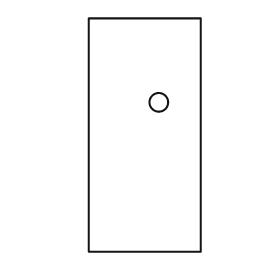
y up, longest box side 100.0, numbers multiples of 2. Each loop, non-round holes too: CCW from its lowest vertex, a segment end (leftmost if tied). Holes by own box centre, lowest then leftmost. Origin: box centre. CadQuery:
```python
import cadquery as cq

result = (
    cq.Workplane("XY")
    .moveTo(-24.0, -50.0)
    .lineTo(24.0, -50.0)
    .lineTo(24.0, 50.0)
    .lineTo(-24.0, 50.0)
    .close()
    .moveTo(6.0, 14.0)
    .circle(4.0)
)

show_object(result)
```